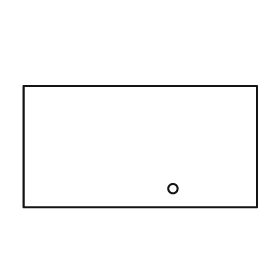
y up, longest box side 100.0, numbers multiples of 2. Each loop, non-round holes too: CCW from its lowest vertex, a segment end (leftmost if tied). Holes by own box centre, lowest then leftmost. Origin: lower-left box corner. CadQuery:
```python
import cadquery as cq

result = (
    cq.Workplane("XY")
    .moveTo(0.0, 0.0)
    .lineTo(100.0, 0.0)
    .lineTo(100.0, 52.0)
    .lineTo(0.0, 52.0)
    .close()
    .moveTo(64.0, 8.0)
    .circle(2.0)
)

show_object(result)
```